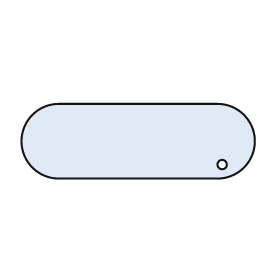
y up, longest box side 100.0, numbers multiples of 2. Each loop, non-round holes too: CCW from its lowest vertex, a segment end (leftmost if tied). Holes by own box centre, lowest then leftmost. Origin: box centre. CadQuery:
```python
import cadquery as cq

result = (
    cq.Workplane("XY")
    .moveTo(-34.0, -16.0)
    .lineTo(34.0, -16.0)
    .threePointArc((50.0, 0.0), (34.0, 16.0))
    .lineTo(-34.0, 16.0)
    .threePointArc((-50.0, 0.0), (-34.0, -16.0))
    .close()
    .moveTo(36.0, -10.0)
    .circle(2.0)
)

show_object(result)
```